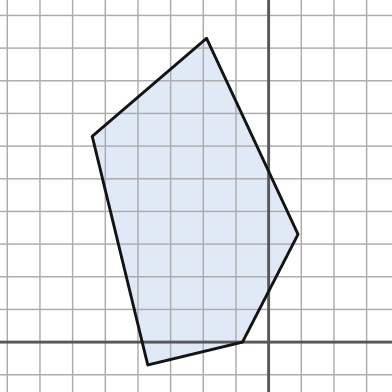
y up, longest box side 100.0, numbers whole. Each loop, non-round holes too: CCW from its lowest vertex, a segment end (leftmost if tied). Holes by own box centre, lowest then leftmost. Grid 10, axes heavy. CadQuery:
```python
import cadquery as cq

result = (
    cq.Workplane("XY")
    .moveTo(-37.0, -7.0)
    .lineTo(-8.0, 0.0)
    .lineTo(9.0, 33.0)
    .lineTo(-19.0, 93.0)
    .lineTo(-54.0, 63.0)
    .close()
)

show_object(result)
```